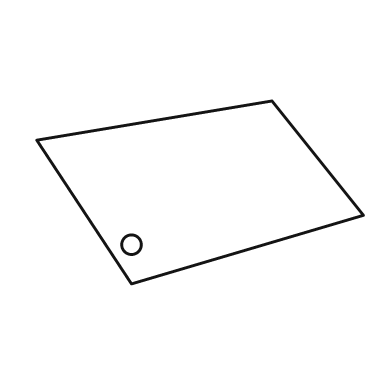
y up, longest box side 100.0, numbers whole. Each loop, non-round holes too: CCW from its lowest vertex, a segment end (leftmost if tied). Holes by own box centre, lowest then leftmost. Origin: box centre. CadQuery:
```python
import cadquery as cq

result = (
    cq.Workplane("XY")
    .moveTo(-21.0, -28.0)
    .lineTo(50.0, -7.0)
    .lineTo(22.0, 28.0)
    .lineTo(-50.0, 16.0)
    .close()
    .moveTo(-21.0, -16.0)
    .circle(3.0)
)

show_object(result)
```